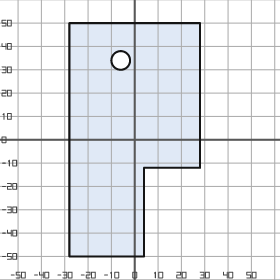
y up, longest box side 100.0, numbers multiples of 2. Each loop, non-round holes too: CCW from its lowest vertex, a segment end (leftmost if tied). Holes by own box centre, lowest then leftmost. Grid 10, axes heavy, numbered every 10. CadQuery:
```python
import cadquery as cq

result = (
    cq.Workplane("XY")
    .moveTo(-28.0, -50.0)
    .lineTo(4.0, -50.0)
    .lineTo(4.0, -12.0)
    .lineTo(28.0, -12.0)
    .lineTo(28.0, 50.0)
    .lineTo(-28.0, 50.0)
    .close()
    .moveTo(-6.0, 34.0)
    .circle(4.0)
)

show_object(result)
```